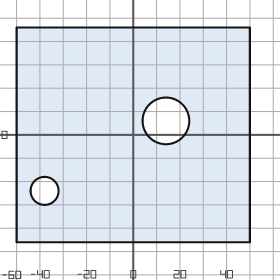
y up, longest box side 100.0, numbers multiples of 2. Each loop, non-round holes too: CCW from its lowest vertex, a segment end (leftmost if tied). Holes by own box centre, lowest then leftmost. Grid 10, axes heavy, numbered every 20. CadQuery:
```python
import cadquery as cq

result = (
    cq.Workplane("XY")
    .moveTo(-50.0, -46.0)
    .lineTo(50.0, -46.0)
    .lineTo(50.0, 46.0)
    .lineTo(-50.0, 46.0)
    .close()
    .moveTo(-38.0, -24.0)
    .circle(6.0)
    .moveTo(14.0, 6.0)
    .circle(10.0)
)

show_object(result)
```